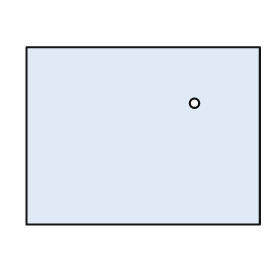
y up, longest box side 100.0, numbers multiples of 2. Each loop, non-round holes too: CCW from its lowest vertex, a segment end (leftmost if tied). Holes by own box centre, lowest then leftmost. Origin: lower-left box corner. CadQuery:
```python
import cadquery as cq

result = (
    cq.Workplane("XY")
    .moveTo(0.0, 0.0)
    .lineTo(100.0, 0.0)
    .lineTo(100.0, 76.0)
    .lineTo(0.0, 76.0)
    .close()
    .moveTo(72.0, 52.0)
    .circle(2.0)
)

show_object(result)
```